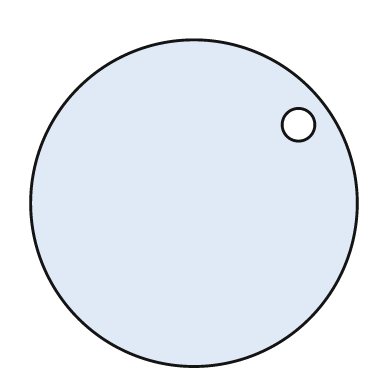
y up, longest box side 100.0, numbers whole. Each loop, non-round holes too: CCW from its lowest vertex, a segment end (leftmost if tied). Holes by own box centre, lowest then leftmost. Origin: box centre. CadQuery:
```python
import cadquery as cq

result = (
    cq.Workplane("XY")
    .moveTo(0.0, 0.0)
    .circle(50.0)
    .moveTo(32.0, 24.0)
    .circle(5.0)
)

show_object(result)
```